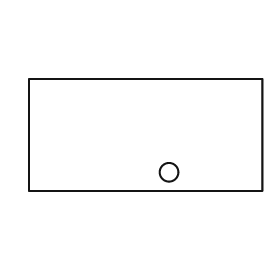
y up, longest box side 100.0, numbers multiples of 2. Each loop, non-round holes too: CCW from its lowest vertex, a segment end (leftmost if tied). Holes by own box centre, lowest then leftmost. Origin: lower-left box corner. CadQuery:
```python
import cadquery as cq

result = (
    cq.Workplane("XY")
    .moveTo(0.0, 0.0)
    .lineTo(100.0, 0.0)
    .lineTo(100.0, 48.0)
    .lineTo(0.0, 48.0)
    .close()
    .moveTo(60.0, 8.0)
    .circle(4.0)
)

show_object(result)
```